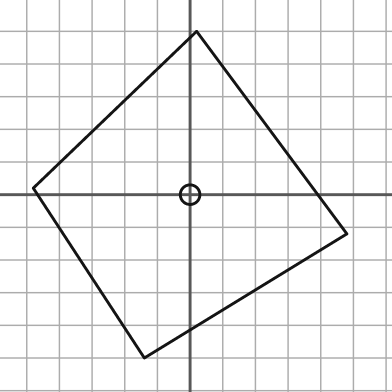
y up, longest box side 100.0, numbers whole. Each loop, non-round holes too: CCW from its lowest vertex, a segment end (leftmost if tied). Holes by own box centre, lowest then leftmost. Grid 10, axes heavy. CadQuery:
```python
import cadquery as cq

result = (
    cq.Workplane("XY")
    .moveTo(-14.0, -50.0)
    .lineTo(48.0, -12.0)
    .lineTo(2.0, 50.0)
    .lineTo(-48.0, 2.0)
    .close()
    .moveTo(0.0, 0.0)
    .circle(3.0)
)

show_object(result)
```